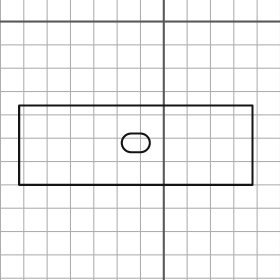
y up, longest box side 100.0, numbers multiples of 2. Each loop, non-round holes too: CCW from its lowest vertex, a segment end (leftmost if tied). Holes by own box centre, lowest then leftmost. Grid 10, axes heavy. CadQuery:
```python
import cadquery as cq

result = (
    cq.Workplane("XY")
    .moveTo(-62.0, -70.0)
    .lineTo(38.0, -70.0)
    .lineTo(38.0, -36.0)
    .lineTo(-62.0, -36.0)
    .close()
    .moveTo(-14.0, -56.0)
    .lineTo(-10.0, -56.0)
    .threePointArc((-6.0, -52.0), (-10.0, -48.0))
    .lineTo(-14.0, -48.0)
    .threePointArc((-18.0, -52.0), (-14.0, -56.0))
    .close()
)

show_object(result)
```